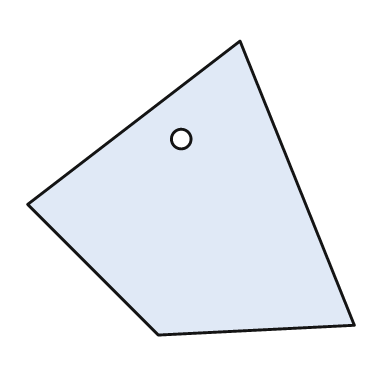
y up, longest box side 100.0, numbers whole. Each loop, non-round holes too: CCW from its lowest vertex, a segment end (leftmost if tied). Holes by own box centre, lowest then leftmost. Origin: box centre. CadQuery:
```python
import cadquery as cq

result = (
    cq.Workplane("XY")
    .moveTo(-10.0, -45.0)
    .lineTo(50.0, -42.0)
    .lineTo(15.0, 45.0)
    .lineTo(-50.0, -5.0)
    .close()
    .moveTo(-3.0, 15.0)
    .circle(3.0)
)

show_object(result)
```